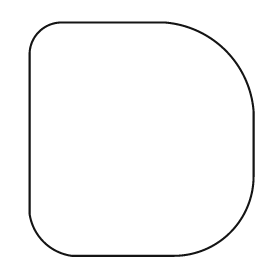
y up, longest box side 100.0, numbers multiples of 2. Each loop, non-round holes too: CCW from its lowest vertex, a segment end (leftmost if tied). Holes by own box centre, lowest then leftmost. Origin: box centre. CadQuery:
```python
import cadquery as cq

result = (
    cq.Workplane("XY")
    .moveTo(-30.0, -50.0)
    .lineTo(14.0, -50.0)
    .threePointArc((38.0, -40.0), (48.0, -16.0))
    .lineTo(48.0, 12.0)
    .threePointArc((36.0, 38.0), (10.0, 50.0))
    .lineTo(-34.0, 50.0)
    .threePointArc((-44.0, 46.0), (-48.0, 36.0))
    .lineTo(-48.0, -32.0)
    .threePointArc((-42.0, -44.0), (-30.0, -50.0))
    .close()
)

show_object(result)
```